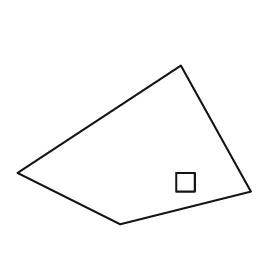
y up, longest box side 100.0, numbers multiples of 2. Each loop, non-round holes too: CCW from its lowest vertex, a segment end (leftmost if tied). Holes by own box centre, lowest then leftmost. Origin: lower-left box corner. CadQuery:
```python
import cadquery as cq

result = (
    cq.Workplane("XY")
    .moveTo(44.0, 0.0)
    .lineTo(100.0, 14.0)
    .lineTo(70.0, 68.0)
    .lineTo(0.0, 22.0)
    .close()
    .moveTo(68.0, 14.0)
    .lineTo(76.0, 14.0)
    .lineTo(76.0, 22.0)
    .lineTo(68.0, 22.0)
    .close()
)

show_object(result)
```